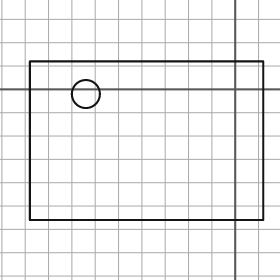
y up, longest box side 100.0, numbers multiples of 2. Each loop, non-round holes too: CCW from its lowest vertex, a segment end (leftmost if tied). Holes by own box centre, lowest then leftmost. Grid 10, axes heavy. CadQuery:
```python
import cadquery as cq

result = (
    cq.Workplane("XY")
    .moveTo(-88.0, -56.0)
    .lineTo(12.0, -56.0)
    .lineTo(12.0, 12.0)
    .lineTo(-88.0, 12.0)
    .close()
    .moveTo(-64.0, -2.0)
    .circle(6.0)
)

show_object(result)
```